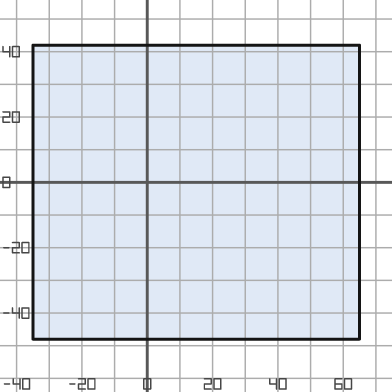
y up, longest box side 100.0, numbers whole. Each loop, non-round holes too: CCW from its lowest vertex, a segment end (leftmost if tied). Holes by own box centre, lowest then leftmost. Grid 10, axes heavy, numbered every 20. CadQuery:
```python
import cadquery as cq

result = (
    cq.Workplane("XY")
    .moveTo(-35.0, -48.0)
    .lineTo(65.0, -48.0)
    .lineTo(65.0, 42.0)
    .lineTo(-35.0, 42.0)
    .close()
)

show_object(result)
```